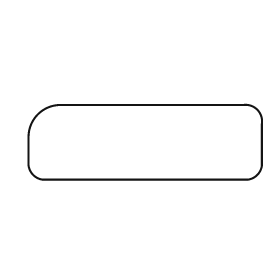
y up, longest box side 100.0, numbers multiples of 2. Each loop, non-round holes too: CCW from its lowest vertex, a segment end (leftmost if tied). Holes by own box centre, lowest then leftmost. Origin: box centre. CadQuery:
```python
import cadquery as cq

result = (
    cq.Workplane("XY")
    .moveTo(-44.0, -16.0)
    .lineTo(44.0, -16.0)
    .threePointArc((48.0, -14.0), (50.0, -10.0))
    .lineTo(50.0, 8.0)
    .threePointArc((48.0, 14.0), (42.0, 16.0))
    .lineTo(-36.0, 16.0)
    .threePointArc((-46.0, 12.0), (-50.0, 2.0))
    .lineTo(-50.0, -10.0)
    .threePointArc((-48.0, -14.0), (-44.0, -16.0))
    .close()
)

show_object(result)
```